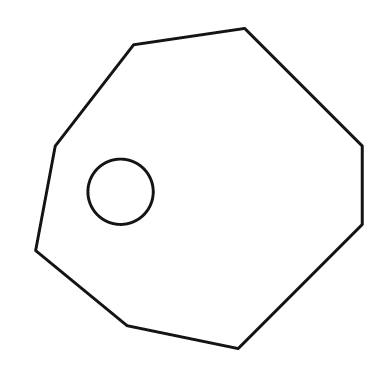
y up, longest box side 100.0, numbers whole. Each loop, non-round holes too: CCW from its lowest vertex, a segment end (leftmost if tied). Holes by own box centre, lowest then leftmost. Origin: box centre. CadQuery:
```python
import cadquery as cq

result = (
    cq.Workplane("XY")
    .moveTo(12.0, -49.0)
    .lineTo(50.0, -11.0)
    .lineTo(50.0, 13.0)
    .lineTo(14.0, 49.0)
    .lineTo(-20.0, 44.0)
    .lineTo(-44.0, 13.0)
    .lineTo(-50.0, -19.0)
    .lineTo(-22.0, -42.0)
    .close()
    .moveTo(-24.0, -1.0)
    .circle(10.0)
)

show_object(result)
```